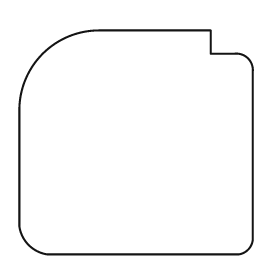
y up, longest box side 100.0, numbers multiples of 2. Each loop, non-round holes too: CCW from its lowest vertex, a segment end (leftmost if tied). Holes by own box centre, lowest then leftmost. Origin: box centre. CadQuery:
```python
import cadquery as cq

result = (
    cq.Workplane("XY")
    .moveTo(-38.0, -48.0)
    .lineTo(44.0, -48.0)
    .threePointArc((48.0, -46.0), (50.0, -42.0))
    .lineTo(50.0, 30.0)
    .threePointArc((48.0, 36.0), (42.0, 38.0))
    .lineTo(32.0, 38.0)
    .lineTo(32.0, 48.0)
    .lineTo(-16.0, 48.0)
    .threePointArc((-40.0, 38.0), (-50.0, 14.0))
    .lineTo(-50.0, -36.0)
    .threePointArc((-46.0, -44.0), (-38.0, -48.0))
    .close()
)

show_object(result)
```